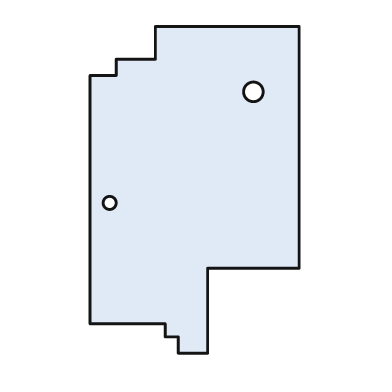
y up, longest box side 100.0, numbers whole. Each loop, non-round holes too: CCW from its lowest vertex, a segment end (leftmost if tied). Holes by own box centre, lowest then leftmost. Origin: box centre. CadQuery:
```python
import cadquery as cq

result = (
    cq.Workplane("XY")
    .moveTo(-5.0, -50.0)
    .lineTo(4.0, -50.0)
    .lineTo(4.0, -24.0)
    .lineTo(32.0, -24.0)
    .lineTo(32.0, 50.0)
    .lineTo(-12.0, 50.0)
    .lineTo(-12.0, 40.0)
    .lineTo(-24.0, 40.0)
    .lineTo(-24.0, 35.0)
    .lineTo(-32.0, 35.0)
    .lineTo(-32.0, -41.0)
    .lineTo(-9.0, -41.0)
    .lineTo(-9.0, -45.0)
    .lineTo(-5.0, -45.0)
    .close()
    .moveTo(-26.0, -4.0)
    .circle(2.0)
    .moveTo(18.0, 30.0)
    .circle(3.0)
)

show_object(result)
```